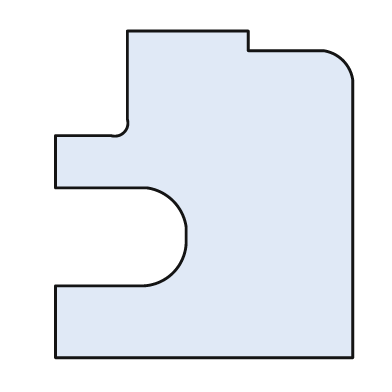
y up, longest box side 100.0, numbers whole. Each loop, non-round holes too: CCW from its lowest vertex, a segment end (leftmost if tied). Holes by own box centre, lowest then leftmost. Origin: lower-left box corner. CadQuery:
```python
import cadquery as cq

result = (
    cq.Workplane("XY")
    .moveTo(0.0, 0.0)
    .lineTo(91.0, 0.0)
    .lineTo(91.0, 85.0)
    .threePointArc((88.0, 91.0), (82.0, 94.0))
    .lineTo(59.0, 94.0)
    .lineTo(59.0, 100.0)
    .lineTo(22.0, 100.0)
    .lineTo(22.0, 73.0)
    .threePointArc((21.0, 69.0), (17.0, 68.0))
    .lineTo(0.0, 68.0)
    .lineTo(0.0, 52.0)
    .lineTo(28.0, 52.0)
    .threePointArc((36.0, 48.0), (40.0, 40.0))
    .lineTo(40.0, 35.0)
    .threePointArc((36.0, 26.0), (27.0, 22.0))
    .lineTo(0.0, 22.0)
    .close()
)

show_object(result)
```